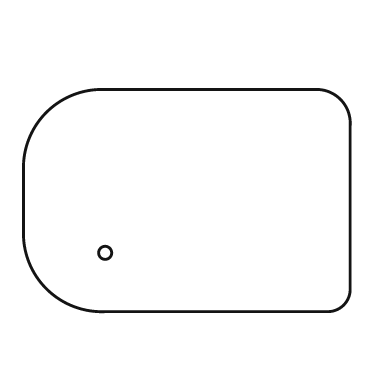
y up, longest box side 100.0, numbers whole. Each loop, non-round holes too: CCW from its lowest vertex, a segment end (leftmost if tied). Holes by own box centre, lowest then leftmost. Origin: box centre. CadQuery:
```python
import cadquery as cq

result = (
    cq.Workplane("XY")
    .moveTo(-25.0, -34.0)
    .lineTo(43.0, -34.0)
    .threePointArc((48.0, -32.0), (50.0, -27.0))
    .lineTo(50.0, 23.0)
    .threePointArc((47.0, 31.0), (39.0, 34.0))
    .lineTo(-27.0, 34.0)
    .threePointArc((-43.0, 27.0), (-50.0, 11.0))
    .lineTo(-50.0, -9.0)
    .threePointArc((-43.0, -27.0), (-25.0, -34.0))
    .close()
    .moveTo(-25.0, -16.0)
    .circle(2.0)
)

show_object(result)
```